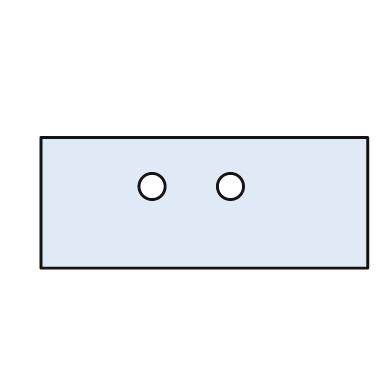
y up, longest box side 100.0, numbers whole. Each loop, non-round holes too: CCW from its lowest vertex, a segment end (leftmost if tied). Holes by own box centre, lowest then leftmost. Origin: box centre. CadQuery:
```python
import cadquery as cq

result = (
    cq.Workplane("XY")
    .moveTo(-50.0, -20.0)
    .lineTo(50.0, -20.0)
    .lineTo(50.0, 20.0)
    .lineTo(-50.0, 20.0)
    .close()
    .moveTo(-16.0, 5.0)
    .circle(4.0)
    .moveTo(8.0, 5.0)
    .circle(4.0)
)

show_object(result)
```